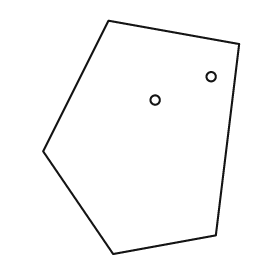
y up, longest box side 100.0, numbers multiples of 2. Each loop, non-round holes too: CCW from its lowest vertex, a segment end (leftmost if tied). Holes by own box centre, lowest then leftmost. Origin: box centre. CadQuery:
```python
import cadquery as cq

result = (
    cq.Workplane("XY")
    .moveTo(-12.0, -50.0)
    .lineTo(32.0, -42.0)
    .lineTo(42.0, 40.0)
    .lineTo(-14.0, 50.0)
    .lineTo(-42.0, -6.0)
    .close()
    .moveTo(6.0, 16.0)
    .circle(2.0)
    .moveTo(30.0, 26.0)
    .circle(2.0)
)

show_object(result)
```